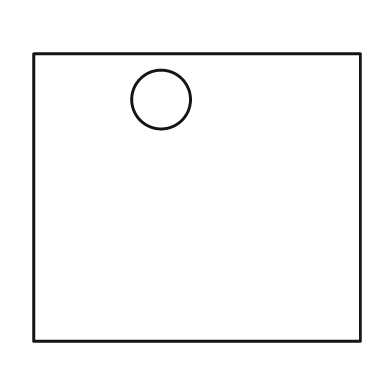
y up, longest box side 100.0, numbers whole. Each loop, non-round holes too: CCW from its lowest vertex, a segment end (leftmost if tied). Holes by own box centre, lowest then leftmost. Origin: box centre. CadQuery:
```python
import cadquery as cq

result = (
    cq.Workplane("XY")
    .moveTo(-50.0, -44.0)
    .lineTo(50.0, -44.0)
    .lineTo(50.0, 44.0)
    .lineTo(-50.0, 44.0)
    .close()
    .moveTo(-11.0, 30.0)
    .circle(9.0)
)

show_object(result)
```